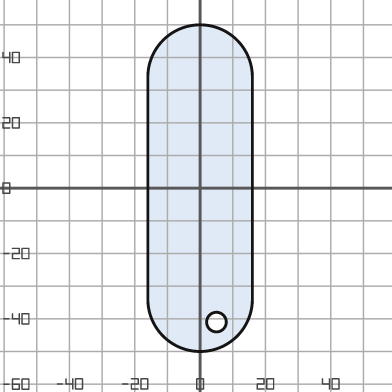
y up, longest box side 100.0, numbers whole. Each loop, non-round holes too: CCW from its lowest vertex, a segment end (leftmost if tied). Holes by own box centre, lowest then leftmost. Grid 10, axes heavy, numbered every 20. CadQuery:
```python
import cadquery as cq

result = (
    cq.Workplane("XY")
    .moveTo(-16.0, -34.0)
    .threePointArc((0.0, -50.0), (16.0, -34.0))
    .lineTo(16.0, 34.0)
    .threePointArc((0.0, 50.0), (-16.0, 34.0))
    .close()
    .moveTo(5.0, -41.0)
    .circle(3.0)
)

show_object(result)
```